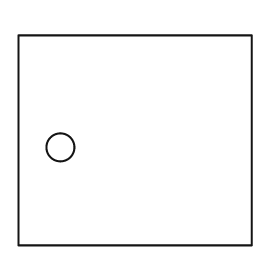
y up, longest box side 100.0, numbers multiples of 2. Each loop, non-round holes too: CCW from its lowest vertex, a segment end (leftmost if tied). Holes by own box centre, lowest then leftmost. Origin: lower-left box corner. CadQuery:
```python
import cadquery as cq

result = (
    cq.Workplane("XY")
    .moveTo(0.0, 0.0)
    .lineTo(100.0, 0.0)
    .lineTo(100.0, 90.0)
    .lineTo(0.0, 90.0)
    .close()
    .moveTo(18.0, 42.0)
    .circle(6.0)
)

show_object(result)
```